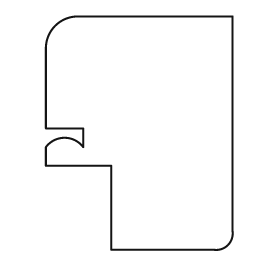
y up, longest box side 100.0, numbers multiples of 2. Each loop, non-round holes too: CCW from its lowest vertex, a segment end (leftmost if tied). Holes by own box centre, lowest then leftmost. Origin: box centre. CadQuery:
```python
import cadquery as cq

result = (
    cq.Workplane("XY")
    .moveTo(-12.0, -50.0)
    .lineTo(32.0, -50.0)
    .threePointArc((38.0, -48.0), (40.0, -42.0))
    .lineTo(40.0, 50.0)
    .lineTo(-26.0, 50.0)
    .threePointArc((-36.0, 46.0), (-40.0, 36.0))
    .lineTo(-40.0, 2.0)
    .lineTo(-24.0, 2.0)
    .lineTo(-24.0, -6.0)
    .threePointArc((-32.0, -2.0), (-40.0, -6.0))
    .lineTo(-40.0, -14.0)
    .lineTo(-12.0, -14.0)
    .close()
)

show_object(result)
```